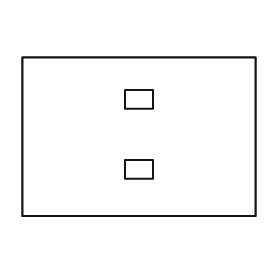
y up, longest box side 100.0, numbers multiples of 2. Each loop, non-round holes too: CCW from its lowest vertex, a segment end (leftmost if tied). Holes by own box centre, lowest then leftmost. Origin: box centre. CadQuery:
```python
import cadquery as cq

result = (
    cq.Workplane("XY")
    .moveTo(-50.0, -34.0)
    .lineTo(50.0, -34.0)
    .lineTo(50.0, 34.0)
    .lineTo(-50.0, 34.0)
    .close()
    .moveTo(-6.0, -18.0)
    .lineTo(6.0, -18.0)
    .lineTo(6.0, -10.0)
    .lineTo(-6.0, -10.0)
    .close()
    .moveTo(-6.0, 12.0)
    .lineTo(6.0, 12.0)
    .lineTo(6.0, 20.0)
    .lineTo(-6.0, 20.0)
    .close()
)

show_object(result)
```